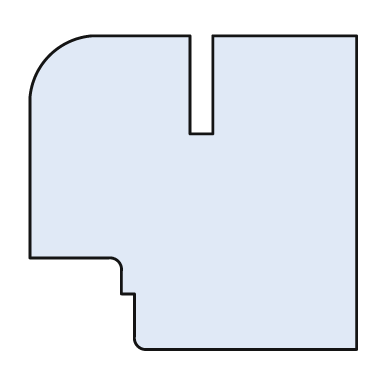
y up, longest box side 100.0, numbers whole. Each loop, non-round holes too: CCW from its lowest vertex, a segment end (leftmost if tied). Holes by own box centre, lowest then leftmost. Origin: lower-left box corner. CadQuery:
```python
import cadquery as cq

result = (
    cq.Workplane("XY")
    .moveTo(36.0, 0.0)
    .lineTo(100.0, 0.0)
    .lineTo(100.0, 96.0)
    .lineTo(56.0, 96.0)
    .lineTo(56.0, 66.0)
    .lineTo(49.0, 66.0)
    .lineTo(49.0, 96.0)
    .lineTo(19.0, 96.0)
    .threePointArc((6.0, 90.0), (0.0, 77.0))
    .lineTo(0.0, 28.0)
    .lineTo(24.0, 28.0)
    .threePointArc((27.0, 27.0), (28.0, 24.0))
    .lineTo(28.0, 17.0)
    .lineTo(32.0, 17.0)
    .lineTo(32.0, 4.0)
    .threePointArc((33.0, 1.0), (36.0, 0.0))
    .close()
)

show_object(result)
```